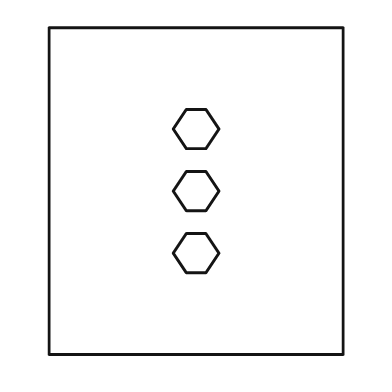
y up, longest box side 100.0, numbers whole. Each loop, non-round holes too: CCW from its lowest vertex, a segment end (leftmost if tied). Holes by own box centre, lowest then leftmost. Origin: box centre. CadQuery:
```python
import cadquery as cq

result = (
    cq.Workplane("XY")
    .moveTo(-45.0, -50.0)
    .lineTo(45.0, -50.0)
    .lineTo(45.0, 50.0)
    .lineTo(-45.0, 50.0)
    .close()
    .moveTo(-3.0, -25.0)
    .lineTo(3.0, -25.0)
    .lineTo(7.0, -19.0)
    .lineTo(3.0, -13.0)
    .lineTo(-3.0, -13.0)
    .lineTo(-7.0, -19.0)
    .close()
    .moveTo(-3.0, -6.0)
    .lineTo(3.0, -6.0)
    .lineTo(7.0, 0.0)
    .lineTo(3.0, 6.0)
    .lineTo(-3.0, 6.0)
    .lineTo(-7.0, 0.0)
    .close()
    .moveTo(-3.0, 13.0)
    .lineTo(3.0, 13.0)
    .lineTo(7.0, 19.0)
    .lineTo(3.0, 25.0)
    .lineTo(-3.0, 25.0)
    .lineTo(-7.0, 19.0)
    .close()
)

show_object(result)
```